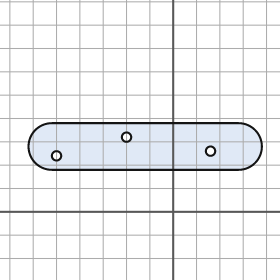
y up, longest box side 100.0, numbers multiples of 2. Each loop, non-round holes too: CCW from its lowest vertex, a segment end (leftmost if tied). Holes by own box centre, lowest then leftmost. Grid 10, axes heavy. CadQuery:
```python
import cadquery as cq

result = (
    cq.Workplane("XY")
    .moveTo(-52.0, 18.0)
    .lineTo(28.0, 18.0)
    .threePointArc((38.0, 28.0), (28.0, 38.0))
    .lineTo(-52.0, 38.0)
    .threePointArc((-62.0, 28.0), (-52.0, 18.0))
    .close()
    .moveTo(-50.0, 24.0)
    .circle(2.0)
    .moveTo(16.0, 26.0)
    .circle(2.0)
    .moveTo(-20.0, 32.0)
    .circle(2.0)
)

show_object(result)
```